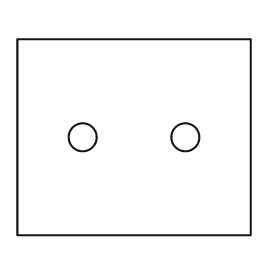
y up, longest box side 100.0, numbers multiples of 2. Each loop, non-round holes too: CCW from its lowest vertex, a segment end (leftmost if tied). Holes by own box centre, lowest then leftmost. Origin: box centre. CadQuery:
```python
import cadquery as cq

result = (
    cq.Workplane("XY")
    .moveTo(-50.0, -42.0)
    .lineTo(50.0, -42.0)
    .lineTo(50.0, 42.0)
    .lineTo(-50.0, 42.0)
    .close()
    .moveTo(-22.0, 0.0)
    .circle(6.0)
    .moveTo(22.0, 0.0)
    .circle(6.0)
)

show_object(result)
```